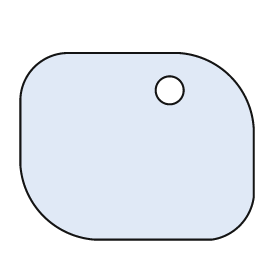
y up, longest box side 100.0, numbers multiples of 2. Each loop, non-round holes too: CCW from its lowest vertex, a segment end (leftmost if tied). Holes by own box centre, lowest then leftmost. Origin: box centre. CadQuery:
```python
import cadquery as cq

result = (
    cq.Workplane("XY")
    .moveTo(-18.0, -40.0)
    .lineTo(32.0, -40.0)
    .threePointArc((44.0, -34.0), (50.0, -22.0))
    .lineTo(50.0, 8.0)
    .threePointArc((40.0, 30.0), (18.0, 40.0))
    .lineTo(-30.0, 40.0)
    .threePointArc((-44.0, 34.0), (-50.0, 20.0))
    .lineTo(-50.0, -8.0)
    .threePointArc((-40.0, -30.0), (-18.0, -40.0))
    .close()
    .moveTo(14.0, 24.0)
    .circle(6.0)
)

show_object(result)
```